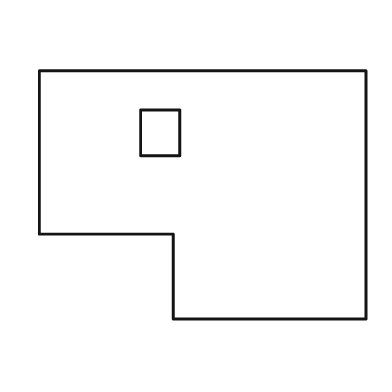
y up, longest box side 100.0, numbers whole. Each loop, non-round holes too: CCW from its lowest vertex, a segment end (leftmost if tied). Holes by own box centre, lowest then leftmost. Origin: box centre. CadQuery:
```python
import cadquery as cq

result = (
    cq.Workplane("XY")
    .moveTo(-9.0, -38.0)
    .lineTo(50.0, -38.0)
    .lineTo(50.0, 38.0)
    .lineTo(-50.0, 38.0)
    .lineTo(-50.0, -12.0)
    .lineTo(-9.0, -12.0)
    .close()
    .moveTo(-19.0, 12.0)
    .lineTo(-7.0, 12.0)
    .lineTo(-7.0, 26.0)
    .lineTo(-19.0, 26.0)
    .close()
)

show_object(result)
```